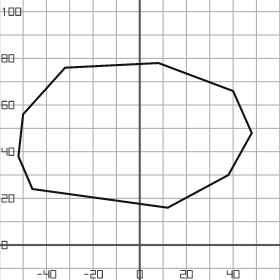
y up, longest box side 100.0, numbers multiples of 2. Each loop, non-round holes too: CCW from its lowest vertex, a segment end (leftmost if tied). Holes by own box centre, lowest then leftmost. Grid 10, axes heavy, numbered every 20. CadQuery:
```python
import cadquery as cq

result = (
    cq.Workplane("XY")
    .moveTo(12.0, 16.0)
    .lineTo(38.0, 30.0)
    .lineTo(48.0, 48.0)
    .lineTo(40.0, 66.0)
    .lineTo(8.0, 78.0)
    .lineTo(-32.0, 76.0)
    .lineTo(-50.0, 56.0)
    .lineTo(-52.0, 38.0)
    .lineTo(-46.0, 24.0)
    .close()
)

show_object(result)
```